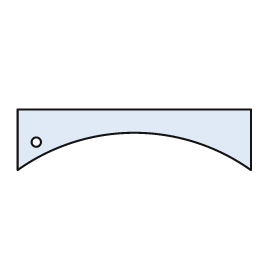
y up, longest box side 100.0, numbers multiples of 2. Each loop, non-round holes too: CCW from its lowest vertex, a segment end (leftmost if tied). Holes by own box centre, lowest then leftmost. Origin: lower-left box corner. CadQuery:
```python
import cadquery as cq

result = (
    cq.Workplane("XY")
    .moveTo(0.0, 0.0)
    .threePointArc((50.0, 16.0), (100.0, 0.0))
    .lineTo(100.0, 26.0)
    .lineTo(0.0, 26.0)
    .close()
    .moveTo(8.0, 12.0)
    .circle(2.0)
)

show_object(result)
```